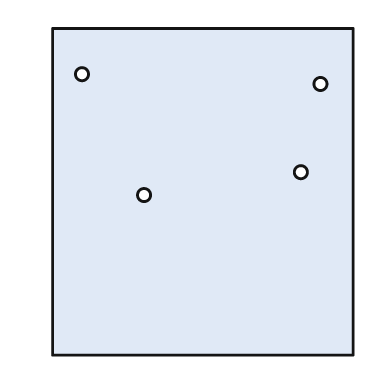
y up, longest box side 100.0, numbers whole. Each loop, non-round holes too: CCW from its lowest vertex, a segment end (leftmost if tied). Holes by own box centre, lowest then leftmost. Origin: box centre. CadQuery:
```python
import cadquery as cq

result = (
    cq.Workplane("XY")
    .moveTo(-46.0, -50.0)
    .lineTo(46.0, -50.0)
    .lineTo(46.0, 50.0)
    .lineTo(-46.0, 50.0)
    .close()
    .moveTo(-18.0, -1.0)
    .circle(2.0)
    .moveTo(30.0, 6.0)
    .circle(2.0)
    .moveTo(36.0, 33.0)
    .circle(2.0)
    .moveTo(-37.0, 36.0)
    .circle(2.0)
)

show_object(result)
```